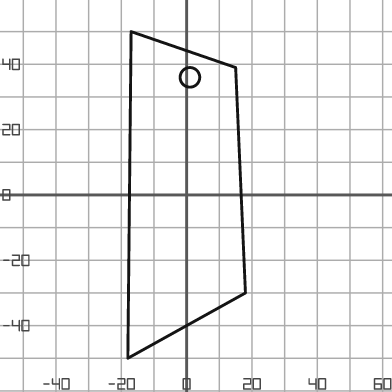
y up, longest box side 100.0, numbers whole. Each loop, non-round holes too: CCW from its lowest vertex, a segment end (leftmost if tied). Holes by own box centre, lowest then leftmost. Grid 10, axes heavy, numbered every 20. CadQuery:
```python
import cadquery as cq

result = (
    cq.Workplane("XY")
    .moveTo(-18.0, -50.0)
    .lineTo(18.0, -30.0)
    .lineTo(15.0, 39.0)
    .lineTo(-17.0, 50.0)
    .close()
    .moveTo(1.0, 36.0)
    .circle(3.0)
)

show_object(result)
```